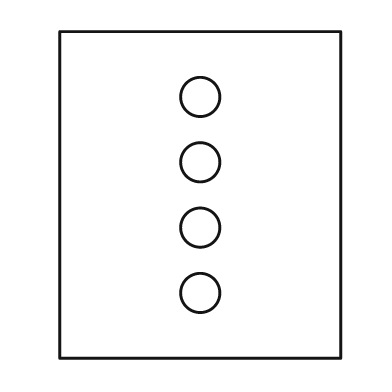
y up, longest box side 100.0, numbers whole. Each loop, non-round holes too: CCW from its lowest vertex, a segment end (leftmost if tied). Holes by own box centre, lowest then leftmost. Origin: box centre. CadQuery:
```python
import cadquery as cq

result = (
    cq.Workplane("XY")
    .moveTo(-43.0, -50.0)
    .lineTo(43.0, -50.0)
    .lineTo(43.0, 50.0)
    .lineTo(-43.0, 50.0)
    .close()
    .moveTo(0.0, -30.0)
    .circle(6.0)
    .moveTo(0.0, -10.0)
    .circle(6.0)
    .moveTo(0.0, 10.0)
    .circle(6.0)
    .moveTo(0.0, 30.0)
    .circle(6.0)
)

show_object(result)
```